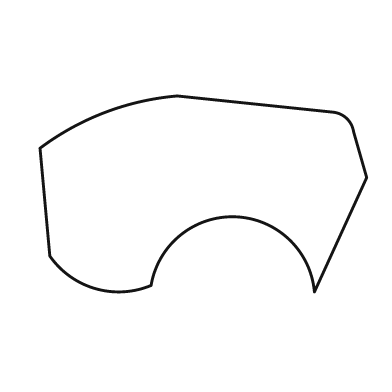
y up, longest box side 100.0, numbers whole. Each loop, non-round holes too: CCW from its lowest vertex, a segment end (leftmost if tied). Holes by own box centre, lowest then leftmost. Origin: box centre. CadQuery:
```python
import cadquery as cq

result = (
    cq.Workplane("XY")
    .moveTo(34.0, -30.0)
    .lineTo(50.0, 5.0)
    .lineTo(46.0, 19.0)
    .threePointArc((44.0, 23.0), (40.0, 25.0))
    .lineTo(-8.0, 30.0)
    .threePointArc((-30.0, 25.0), (-50.0, 14.0))
    .lineTo(-47.0, -19.0)
    .threePointArc((-33.0, -29.0), (-16.0, -28.0))
    .threePointArc((10.0, -7.0), (34.0, -30.0))
    .close()
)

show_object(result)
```